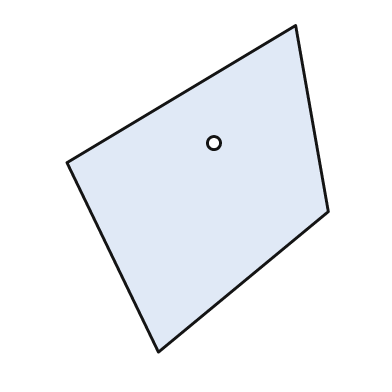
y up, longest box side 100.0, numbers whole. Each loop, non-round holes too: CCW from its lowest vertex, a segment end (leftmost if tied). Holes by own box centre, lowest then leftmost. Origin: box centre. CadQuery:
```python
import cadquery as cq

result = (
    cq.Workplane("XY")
    .moveTo(-12.0, -50.0)
    .lineTo(40.0, -7.0)
    .lineTo(30.0, 50.0)
    .lineTo(-40.0, 8.0)
    .close()
    .moveTo(5.0, 14.0)
    .circle(2.0)
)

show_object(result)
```